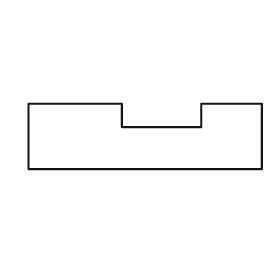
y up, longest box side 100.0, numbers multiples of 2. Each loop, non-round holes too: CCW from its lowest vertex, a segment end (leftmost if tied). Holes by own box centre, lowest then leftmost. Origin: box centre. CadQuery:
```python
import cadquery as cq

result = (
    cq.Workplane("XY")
    .moveTo(-50.0, -14.0)
    .lineTo(50.0, -14.0)
    .lineTo(50.0, 14.0)
    .lineTo(24.0, 14.0)
    .lineTo(24.0, 4.0)
    .lineTo(-10.0, 4.0)
    .lineTo(-10.0, 14.0)
    .lineTo(-50.0, 14.0)
    .close()
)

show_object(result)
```